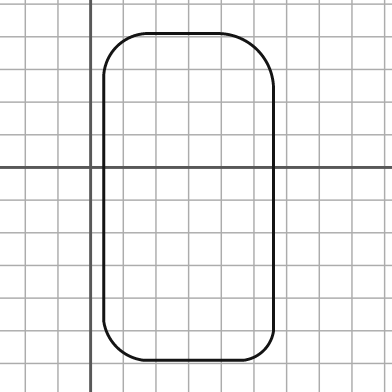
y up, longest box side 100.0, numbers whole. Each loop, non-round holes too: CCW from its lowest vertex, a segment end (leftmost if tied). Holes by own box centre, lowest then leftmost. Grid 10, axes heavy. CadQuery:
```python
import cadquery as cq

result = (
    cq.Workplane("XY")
    .moveTo(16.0, -59.0)
    .lineTo(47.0, -59.0)
    .threePointArc((53.0, -56.0), (56.0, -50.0))
    .lineTo(56.0, 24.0)
    .threePointArc((51.0, 36.0), (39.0, 41.0))
    .lineTo(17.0, 41.0)
    .threePointArc((8.0, 37.0), (4.0, 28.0))
    .lineTo(4.0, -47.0)
    .threePointArc((8.0, -55.0), (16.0, -59.0))
    .close()
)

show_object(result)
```